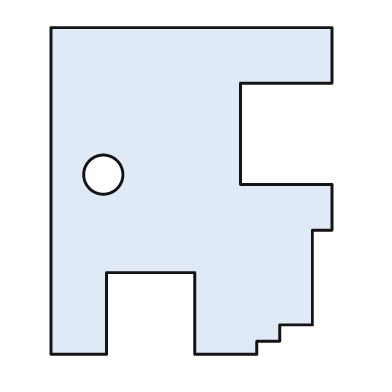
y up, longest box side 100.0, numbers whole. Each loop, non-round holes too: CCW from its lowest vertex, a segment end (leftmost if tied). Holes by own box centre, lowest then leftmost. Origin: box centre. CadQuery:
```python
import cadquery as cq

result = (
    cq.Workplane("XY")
    .moveTo(-43.0, -50.0)
    .lineTo(-26.0, -50.0)
    .lineTo(-26.0, -25.0)
    .lineTo(1.0, -25.0)
    .lineTo(1.0, -50.0)
    .lineTo(20.0, -50.0)
    .lineTo(20.0, -46.0)
    .lineTo(27.0, -46.0)
    .lineTo(27.0, -41.0)
    .lineTo(37.0, -41.0)
    .lineTo(37.0, -12.0)
    .lineTo(43.0, -12.0)
    .lineTo(43.0, 2.0)
    .lineTo(15.0, 2.0)
    .lineTo(15.0, 33.0)
    .lineTo(43.0, 33.0)
    .lineTo(43.0, 50.0)
    .lineTo(-43.0, 50.0)
    .close()
    .moveTo(-27.0, 5.0)
    .circle(6.0)
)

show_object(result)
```